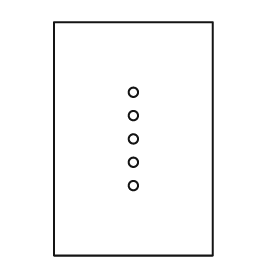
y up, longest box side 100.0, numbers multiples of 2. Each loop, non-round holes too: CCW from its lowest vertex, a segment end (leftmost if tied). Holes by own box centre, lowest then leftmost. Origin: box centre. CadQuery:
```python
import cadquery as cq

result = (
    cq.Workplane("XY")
    .moveTo(-34.0, -50.0)
    .lineTo(34.0, -50.0)
    .lineTo(34.0, 50.0)
    .lineTo(-34.0, 50.0)
    .close()
    .moveTo(0.0, -20.0)
    .circle(2.0)
    .moveTo(0.0, -10.0)
    .circle(2.0)
    .moveTo(0.0, 0.0)
    .circle(2.0)
    .moveTo(0.0, 10.0)
    .circle(2.0)
    .moveTo(0.0, 20.0)
    .circle(2.0)
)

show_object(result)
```